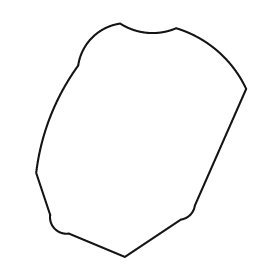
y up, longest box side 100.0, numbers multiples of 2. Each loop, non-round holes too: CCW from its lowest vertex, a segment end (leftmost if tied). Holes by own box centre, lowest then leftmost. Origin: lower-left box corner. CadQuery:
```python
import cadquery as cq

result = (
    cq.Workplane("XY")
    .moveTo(38.0, 0.0)
    .lineTo(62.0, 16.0)
    .threePointArc((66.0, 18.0), (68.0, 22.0))
    .lineTo(90.0, 72.0)
    .threePointArc((78.0, 88.0), (60.0, 98.0))
    .threePointArc((48.0, 96.0), (36.0, 100.0))
    .threePointArc((24.0, 94.0), (18.0, 82.0))
    .threePointArc((6.0, 60.0), (0.0, 36.0))
    .lineTo(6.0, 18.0)
    .threePointArc((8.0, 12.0), (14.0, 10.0))
    .close()
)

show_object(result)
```